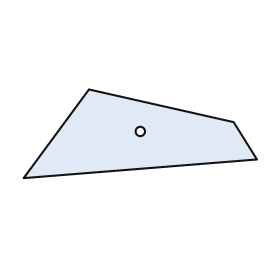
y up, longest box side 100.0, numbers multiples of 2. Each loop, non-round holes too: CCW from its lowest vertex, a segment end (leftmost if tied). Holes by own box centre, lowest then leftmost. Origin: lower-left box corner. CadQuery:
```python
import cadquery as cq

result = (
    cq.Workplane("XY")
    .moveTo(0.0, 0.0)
    .lineTo(100.0, 8.0)
    .lineTo(90.0, 24.0)
    .lineTo(28.0, 38.0)
    .close()
    .moveTo(50.0, 20.0)
    .circle(2.0)
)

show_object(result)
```